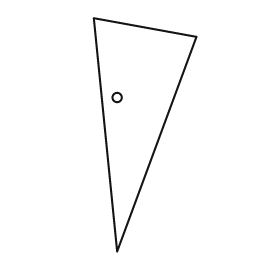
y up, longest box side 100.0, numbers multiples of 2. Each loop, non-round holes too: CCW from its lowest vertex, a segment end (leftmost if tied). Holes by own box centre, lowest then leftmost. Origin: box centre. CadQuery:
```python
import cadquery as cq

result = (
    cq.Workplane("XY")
    .moveTo(-12.0, -50.0)
    .lineTo(22.0, 42.0)
    .lineTo(-22.0, 50.0)
    .close()
    .moveTo(-12.0, 16.0)
    .circle(2.0)
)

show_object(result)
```